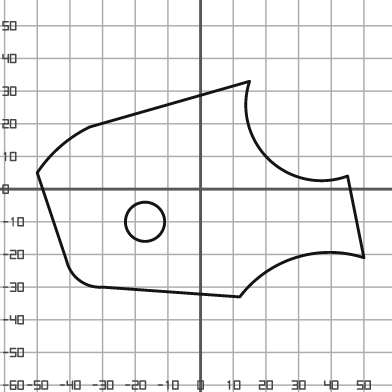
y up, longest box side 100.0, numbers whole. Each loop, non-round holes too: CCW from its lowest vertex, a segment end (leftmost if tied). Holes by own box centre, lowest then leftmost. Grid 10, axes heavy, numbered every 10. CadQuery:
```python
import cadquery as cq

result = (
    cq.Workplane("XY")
    .moveTo(12.0, -33.0)
    .threePointArc((29.0, -21.0), (50.0, -21.0))
    .lineTo(45.0, 4.0)
    .threePointArc((21.0, 9.0), (15.0, 33.0))
    .lineTo(-34.0, 19.0)
    .threePointArc((-43.0, 13.0), (-50.0, 5.0))
    .lineTo(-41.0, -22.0)
    .threePointArc((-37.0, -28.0), (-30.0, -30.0))
    .close()
    .moveTo(-17.0, -10.0)
    .circle(6.0)
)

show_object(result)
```